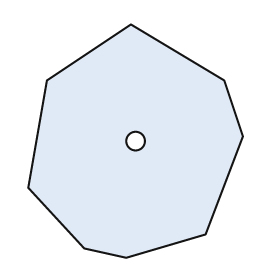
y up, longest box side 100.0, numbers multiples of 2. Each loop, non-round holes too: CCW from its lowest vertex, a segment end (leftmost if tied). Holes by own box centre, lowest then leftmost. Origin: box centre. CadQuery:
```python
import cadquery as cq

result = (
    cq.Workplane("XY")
    .moveTo(-4.0, -50.0)
    .lineTo(30.0, -40.0)
    .lineTo(46.0, 2.0)
    .lineTo(38.0, 26.0)
    .lineTo(-2.0, 50.0)
    .lineTo(-38.0, 26.0)
    .lineTo(-46.0, -20.0)
    .lineTo(-22.0, -46.0)
    .close()
    .moveTo(0.0, 0.0)
    .circle(4.0)
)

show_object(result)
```